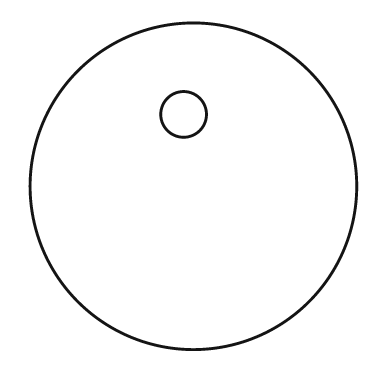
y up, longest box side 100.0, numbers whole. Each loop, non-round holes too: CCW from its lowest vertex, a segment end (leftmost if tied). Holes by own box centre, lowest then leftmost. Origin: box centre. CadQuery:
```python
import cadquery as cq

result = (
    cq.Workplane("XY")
    .moveTo(0.0, 0.0)
    .circle(50.0)
    .moveTo(-3.0, 22.0)
    .circle(7.0)
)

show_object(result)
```